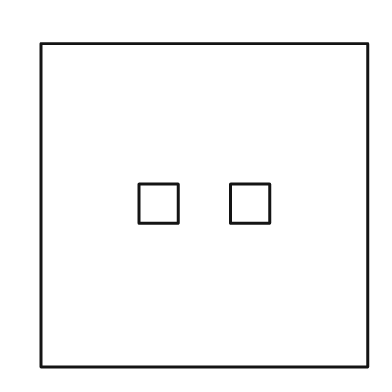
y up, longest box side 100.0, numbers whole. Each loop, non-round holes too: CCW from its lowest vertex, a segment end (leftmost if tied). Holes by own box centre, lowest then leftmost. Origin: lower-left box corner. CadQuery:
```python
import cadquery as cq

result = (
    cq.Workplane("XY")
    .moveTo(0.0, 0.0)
    .lineTo(100.0, 0.0)
    .lineTo(100.0, 99.0)
    .lineTo(0.0, 99.0)
    .close()
    .moveTo(30.0, 44.0)
    .lineTo(42.0, 44.0)
    .lineTo(42.0, 56.0)
    .lineTo(30.0, 56.0)
    .close()
    .moveTo(58.0, 44.0)
    .lineTo(70.0, 44.0)
    .lineTo(70.0, 56.0)
    .lineTo(58.0, 56.0)
    .close()
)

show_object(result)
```